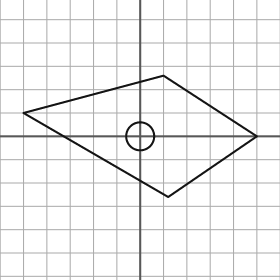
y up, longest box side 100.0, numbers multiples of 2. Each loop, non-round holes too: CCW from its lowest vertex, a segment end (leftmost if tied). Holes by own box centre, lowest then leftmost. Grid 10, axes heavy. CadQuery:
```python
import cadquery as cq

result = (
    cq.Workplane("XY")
    .moveTo(12.0, -26.0)
    .lineTo(50.0, 0.0)
    .lineTo(10.0, 26.0)
    .lineTo(-50.0, 10.0)
    .close()
    .moveTo(0.0, 0.0)
    .circle(6.0)
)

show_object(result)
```